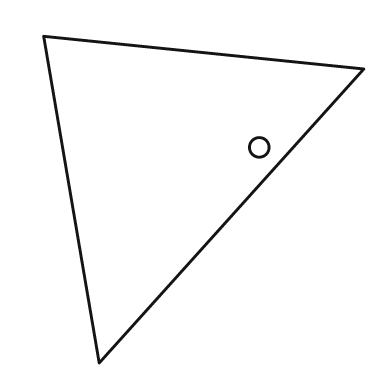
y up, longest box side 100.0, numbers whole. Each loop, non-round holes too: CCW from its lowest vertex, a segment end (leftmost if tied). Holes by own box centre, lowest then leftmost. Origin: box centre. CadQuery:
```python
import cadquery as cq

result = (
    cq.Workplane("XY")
    .moveTo(-32.0, -50.0)
    .lineTo(49.0, 40.0)
    .lineTo(-49.0, 50.0)
    .close()
    .moveTo(17.0, 16.0)
    .circle(3.0)
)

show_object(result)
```